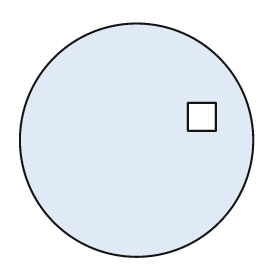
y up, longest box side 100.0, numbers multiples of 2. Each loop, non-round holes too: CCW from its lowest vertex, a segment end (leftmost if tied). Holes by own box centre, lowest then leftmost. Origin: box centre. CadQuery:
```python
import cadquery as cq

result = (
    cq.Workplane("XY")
    .moveTo(0.0, 0.0)
    .circle(50.0)
    .moveTo(22.0, 4.0)
    .lineTo(34.0, 4.0)
    .lineTo(34.0, 16.0)
    .lineTo(22.0, 16.0)
    .close()
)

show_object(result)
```